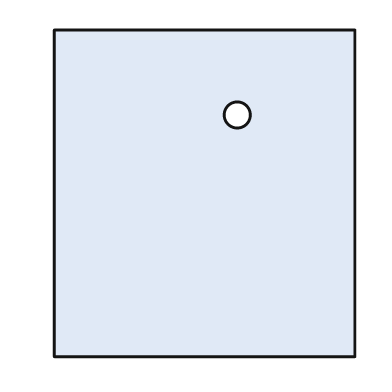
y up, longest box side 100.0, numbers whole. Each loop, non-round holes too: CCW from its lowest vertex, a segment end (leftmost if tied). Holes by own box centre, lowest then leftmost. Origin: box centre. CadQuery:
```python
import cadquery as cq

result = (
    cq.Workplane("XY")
    .moveTo(-46.0, -50.0)
    .lineTo(46.0, -50.0)
    .lineTo(46.0, 50.0)
    .lineTo(-46.0, 50.0)
    .close()
    .moveTo(10.0, 24.0)
    .circle(4.0)
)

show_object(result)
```